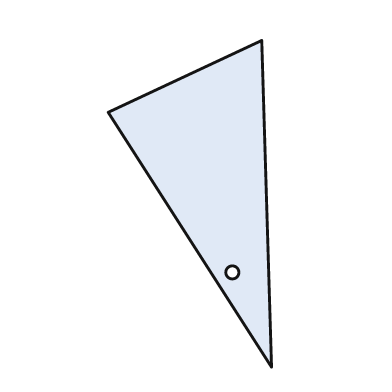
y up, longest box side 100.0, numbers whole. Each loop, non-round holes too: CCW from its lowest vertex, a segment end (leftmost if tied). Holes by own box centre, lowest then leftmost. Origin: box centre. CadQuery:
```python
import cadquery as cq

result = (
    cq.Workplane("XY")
    .moveTo(25.0, -50.0)
    .lineTo(22.0, 50.0)
    .lineTo(-25.0, 28.0)
    .close()
    .moveTo(13.0, -21.0)
    .circle(2.0)
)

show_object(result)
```